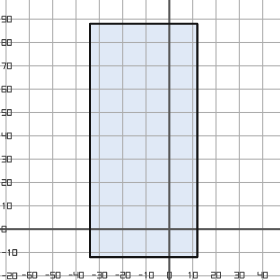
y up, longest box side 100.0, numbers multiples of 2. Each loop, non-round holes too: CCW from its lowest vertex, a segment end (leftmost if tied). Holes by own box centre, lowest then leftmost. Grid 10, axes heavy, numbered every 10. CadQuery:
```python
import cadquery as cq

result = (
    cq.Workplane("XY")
    .moveTo(-34.0, -12.0)
    .lineTo(12.0, -12.0)
    .lineTo(12.0, 88.0)
    .lineTo(-34.0, 88.0)
    .close()
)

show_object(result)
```